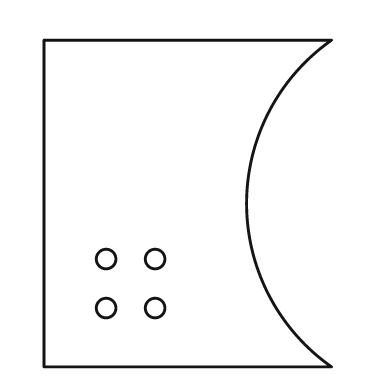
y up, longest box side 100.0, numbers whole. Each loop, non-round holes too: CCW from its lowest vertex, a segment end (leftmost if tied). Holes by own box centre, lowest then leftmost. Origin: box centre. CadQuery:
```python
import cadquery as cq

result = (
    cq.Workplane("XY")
    .moveTo(-44.0, -50.0)
    .lineTo(44.0, -50.0)
    .threePointArc((18.0, 0.0), (44.0, 50.0))
    .lineTo(-44.0, 50.0)
    .close()
    .moveTo(-25.0, -32.0)
    .circle(3.0)
    .moveTo(-10.0, -32.0)
    .circle(3.0)
    .moveTo(-25.0, -17.0)
    .circle(3.0)
    .moveTo(-10.0, -17.0)
    .circle(3.0)
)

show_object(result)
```